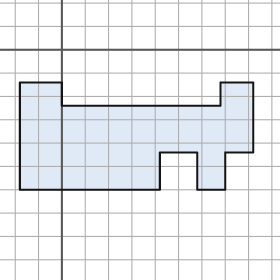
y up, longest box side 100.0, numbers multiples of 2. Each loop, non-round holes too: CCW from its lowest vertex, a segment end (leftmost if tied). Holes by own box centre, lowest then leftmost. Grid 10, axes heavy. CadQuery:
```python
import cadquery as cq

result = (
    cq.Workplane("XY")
    .moveTo(-18.0, -60.0)
    .lineTo(42.0, -60.0)
    .lineTo(42.0, -44.0)
    .lineTo(58.0, -44.0)
    .lineTo(58.0, -60.0)
    .lineTo(70.0, -60.0)
    .lineTo(70.0, -44.0)
    .lineTo(82.0, -44.0)
    .lineTo(82.0, -14.0)
    .lineTo(68.0, -14.0)
    .lineTo(68.0, -24.0)
    .lineTo(0.0, -24.0)
    .lineTo(0.0, -14.0)
    .lineTo(-18.0, -14.0)
    .close()
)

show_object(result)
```